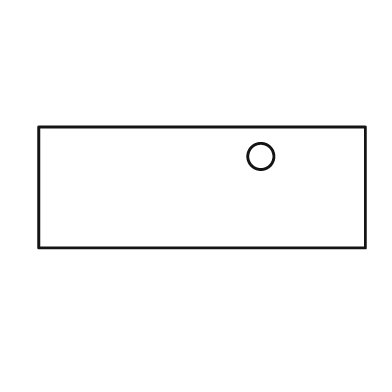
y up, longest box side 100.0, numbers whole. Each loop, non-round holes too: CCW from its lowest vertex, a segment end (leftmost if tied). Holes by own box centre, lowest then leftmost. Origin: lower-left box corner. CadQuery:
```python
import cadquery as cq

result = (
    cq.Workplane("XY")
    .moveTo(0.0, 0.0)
    .lineTo(100.0, 0.0)
    .lineTo(100.0, 37.0)
    .lineTo(0.0, 37.0)
    .close()
    .moveTo(68.0, 28.0)
    .circle(4.0)
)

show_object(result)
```